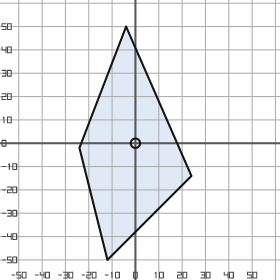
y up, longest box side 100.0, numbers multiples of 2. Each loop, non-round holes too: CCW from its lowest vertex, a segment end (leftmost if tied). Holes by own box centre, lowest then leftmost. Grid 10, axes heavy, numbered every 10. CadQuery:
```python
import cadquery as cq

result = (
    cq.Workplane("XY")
    .moveTo(-12.0, -50.0)
    .lineTo(24.0, -14.0)
    .lineTo(-4.0, 50.0)
    .lineTo(-24.0, -2.0)
    .close()
    .moveTo(0.0, 0.0)
    .circle(2.0)
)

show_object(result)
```